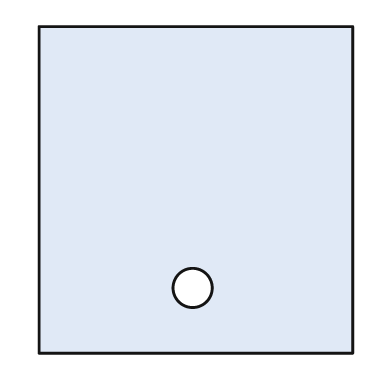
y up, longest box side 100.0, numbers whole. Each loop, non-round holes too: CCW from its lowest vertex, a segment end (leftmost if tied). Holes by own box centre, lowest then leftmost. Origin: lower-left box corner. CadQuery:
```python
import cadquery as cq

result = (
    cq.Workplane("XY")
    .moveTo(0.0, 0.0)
    .lineTo(96.0, 0.0)
    .lineTo(96.0, 100.0)
    .lineTo(0.0, 100.0)
    .close()
    .moveTo(47.0, 20.0)
    .circle(6.0)
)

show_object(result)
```